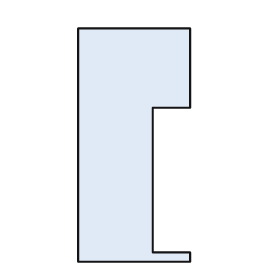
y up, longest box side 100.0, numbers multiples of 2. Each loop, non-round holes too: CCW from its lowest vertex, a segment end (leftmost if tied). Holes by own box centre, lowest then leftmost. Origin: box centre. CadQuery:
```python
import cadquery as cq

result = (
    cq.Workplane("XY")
    .moveTo(-24.0, -50.0)
    .lineTo(24.0, -50.0)
    .lineTo(24.0, -46.0)
    .lineTo(8.0, -46.0)
    .lineTo(8.0, 16.0)
    .lineTo(24.0, 16.0)
    .lineTo(24.0, 50.0)
    .lineTo(-24.0, 50.0)
    .close()
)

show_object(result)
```